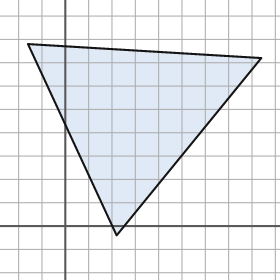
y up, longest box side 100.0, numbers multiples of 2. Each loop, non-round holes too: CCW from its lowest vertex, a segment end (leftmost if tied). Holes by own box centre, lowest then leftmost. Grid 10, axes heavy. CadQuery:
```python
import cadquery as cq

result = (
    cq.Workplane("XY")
    .moveTo(22.0, -4.0)
    .lineTo(84.0, 72.0)
    .lineTo(-16.0, 78.0)
    .close()
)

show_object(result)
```